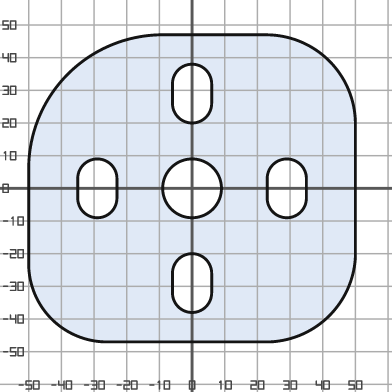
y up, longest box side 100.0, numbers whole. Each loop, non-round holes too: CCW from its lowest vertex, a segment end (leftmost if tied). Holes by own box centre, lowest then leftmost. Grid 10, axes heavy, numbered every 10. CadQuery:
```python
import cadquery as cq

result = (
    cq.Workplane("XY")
    .moveTo(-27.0, -47.0)
    .lineTo(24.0, -47.0)
    .threePointArc((42.0, -39.0), (50.0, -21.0))
    .lineTo(50.0, 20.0)
    .threePointArc((42.0, 39.0), (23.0, 47.0))
    .lineTo(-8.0, 47.0)
    .threePointArc((-38.0, 35.0), (-50.0, 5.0))
    .lineTo(-50.0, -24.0)
    .threePointArc((-43.0, -40.0), (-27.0, -47.0))
    .close()
    .moveTo(-6.0, -32.0)
    .threePointArc((0.0, -38.0), (6.0, -32.0))
    .lineTo(6.0, -26.0)
    .threePointArc((0.0, -20.0), (-6.0, -26.0))
    .close()
    .moveTo(-35.0, -3.0)
    .threePointArc((-29.0, -9.0), (-23.0, -3.0))
    .lineTo(-23.0, 3.0)
    .threePointArc((-29.0, 9.0), (-35.0, 3.0))
    .close()
    .moveTo(0.0, 0.0)
    .circle(9.0)
    .moveTo(23.0, -3.0)
    .threePointArc((29.0, -9.0), (35.0, -3.0))
    .lineTo(35.0, 3.0)
    .threePointArc((29.0, 9.0), (23.0, 3.0))
    .close()
    .moveTo(-6.0, 26.0)
    .threePointArc((0.0, 20.0), (6.0, 26.0))
    .lineTo(6.0, 32.0)
    .threePointArc((0.0, 38.0), (-6.0, 32.0))
    .close()
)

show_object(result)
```